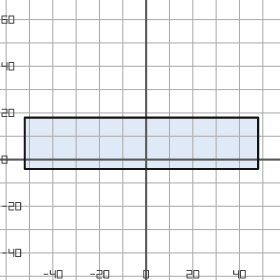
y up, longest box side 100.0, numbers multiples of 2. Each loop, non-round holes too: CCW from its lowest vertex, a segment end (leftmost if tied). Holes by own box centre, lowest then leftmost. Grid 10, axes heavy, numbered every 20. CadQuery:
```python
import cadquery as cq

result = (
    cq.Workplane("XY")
    .moveTo(-52.0, -4.0)
    .lineTo(48.0, -4.0)
    .lineTo(48.0, 18.0)
    .lineTo(-52.0, 18.0)
    .close()
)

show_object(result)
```